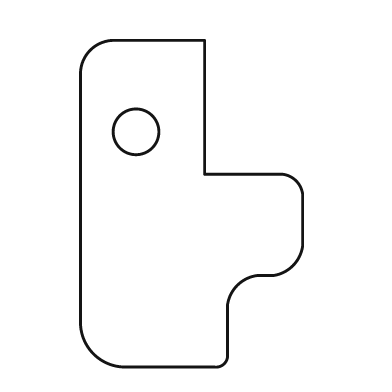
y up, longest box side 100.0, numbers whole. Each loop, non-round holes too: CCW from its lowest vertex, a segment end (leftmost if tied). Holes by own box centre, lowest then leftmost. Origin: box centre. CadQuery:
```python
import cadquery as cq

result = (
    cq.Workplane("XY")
    .moveTo(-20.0, -50.0)
    .lineTo(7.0, -50.0)
    .threePointArc((10.0, -49.0), (11.0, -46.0))
    .lineTo(11.0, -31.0)
    .threePointArc((14.0, -25.0), (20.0, -22.0))
    .lineTo(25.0, -22.0)
    .threePointArc((31.0, -19.0), (34.0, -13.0))
    .lineTo(34.0, 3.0)
    .threePointArc((32.0, 7.0), (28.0, 9.0))
    .lineTo(4.0, 9.0)
    .lineTo(4.0, 50.0)
    .lineTo(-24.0, 50.0)
    .threePointArc((-31.0, 47.0), (-34.0, 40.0))
    .lineTo(-34.0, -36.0)
    .threePointArc((-30.0, -46.0), (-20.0, -50.0))
    .close()
    .moveTo(-17.0, 22.0)
    .circle(7.0)
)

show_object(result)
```